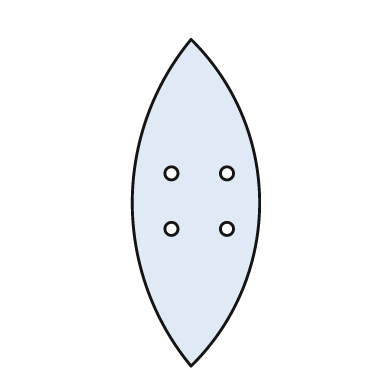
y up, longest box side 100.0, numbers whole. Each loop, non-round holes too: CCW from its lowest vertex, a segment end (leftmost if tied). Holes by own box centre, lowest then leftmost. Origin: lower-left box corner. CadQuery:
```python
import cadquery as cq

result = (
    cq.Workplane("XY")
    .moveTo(18.0, 0.0)
    .threePointArc((39.0, 50.0), (18.0, 100.0))
    .threePointArc((0.0, 50.0), (18.0, 0.0))
    .close()
    .moveTo(12.0, 42.0)
    .circle(2.0)
    .moveTo(29.0, 42.0)
    .circle(2.0)
    .moveTo(12.0, 59.0)
    .circle(2.0)
    .moveTo(29.0, 59.0)
    .circle(2.0)
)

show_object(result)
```